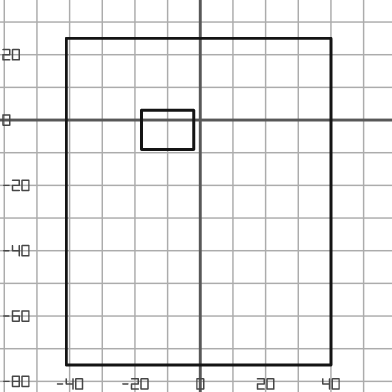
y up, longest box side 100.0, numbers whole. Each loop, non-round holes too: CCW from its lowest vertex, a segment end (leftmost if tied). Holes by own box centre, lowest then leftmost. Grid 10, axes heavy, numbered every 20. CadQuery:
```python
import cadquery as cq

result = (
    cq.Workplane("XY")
    .moveTo(-41.0, -75.0)
    .lineTo(40.0, -75.0)
    .lineTo(40.0, 25.0)
    .lineTo(-41.0, 25.0)
    .close()
    .moveTo(-18.0, -9.0)
    .lineTo(-2.0, -9.0)
    .lineTo(-2.0, 3.0)
    .lineTo(-18.0, 3.0)
    .close()
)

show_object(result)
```